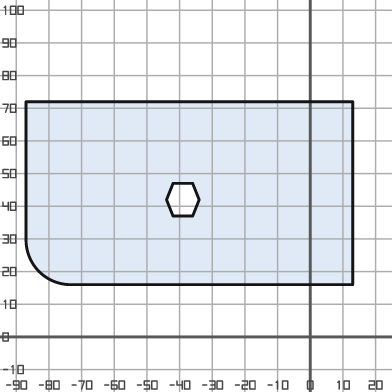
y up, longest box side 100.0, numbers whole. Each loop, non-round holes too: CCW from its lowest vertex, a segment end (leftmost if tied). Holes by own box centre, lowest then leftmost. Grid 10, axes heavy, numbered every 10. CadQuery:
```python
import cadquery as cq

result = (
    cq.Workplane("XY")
    .moveTo(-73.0, 16.0)
    .lineTo(13.0, 16.0)
    .lineTo(13.0, 72.0)
    .lineTo(-87.0, 72.0)
    .lineTo(-87.0, 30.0)
    .threePointArc((-83.0, 20.0), (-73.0, 16.0))
    .close()
    .moveTo(-42.0, 37.0)
    .lineTo(-36.0, 37.0)
    .lineTo(-34.0, 42.0)
    .lineTo(-36.0, 47.0)
    .lineTo(-42.0, 47.0)
    .lineTo(-44.0, 42.0)
    .close()
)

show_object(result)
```